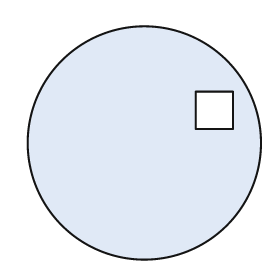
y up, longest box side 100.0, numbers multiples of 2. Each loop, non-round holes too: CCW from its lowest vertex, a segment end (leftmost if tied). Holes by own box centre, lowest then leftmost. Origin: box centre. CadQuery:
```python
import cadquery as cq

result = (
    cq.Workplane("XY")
    .moveTo(0.0, 0.0)
    .circle(50.0)
    .moveTo(22.0, 6.0)
    .lineTo(38.0, 6.0)
    .lineTo(38.0, 22.0)
    .lineTo(22.0, 22.0)
    .close()
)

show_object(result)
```